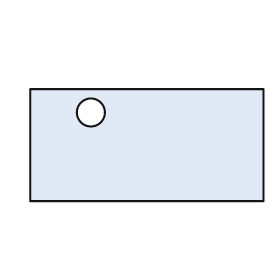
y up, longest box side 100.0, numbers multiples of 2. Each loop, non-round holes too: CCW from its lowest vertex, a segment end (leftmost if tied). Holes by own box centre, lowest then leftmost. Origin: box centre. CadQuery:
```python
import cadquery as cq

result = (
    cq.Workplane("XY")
    .moveTo(-50.0, -24.0)
    .lineTo(50.0, -24.0)
    .lineTo(50.0, 24.0)
    .lineTo(-50.0, 24.0)
    .close()
    .moveTo(-24.0, 14.0)
    .circle(6.0)
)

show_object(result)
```